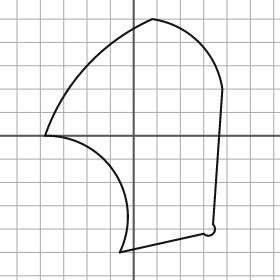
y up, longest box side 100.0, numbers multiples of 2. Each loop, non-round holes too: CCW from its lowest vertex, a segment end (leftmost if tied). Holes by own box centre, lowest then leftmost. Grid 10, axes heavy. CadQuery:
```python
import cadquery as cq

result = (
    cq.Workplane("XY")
    .moveTo(-6.0, -50.0)
    .lineTo(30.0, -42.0)
    .threePointArc((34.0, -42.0), (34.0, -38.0))
    .lineTo(38.0, 20.0)
    .threePointArc((28.0, 40.0), (8.0, 50.0))
    .threePointArc((-20.0, 30.0), (-38.0, 0.0))
    .threePointArc((-8.0, -16.0), (-6.0, -50.0))
    .close()
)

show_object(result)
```